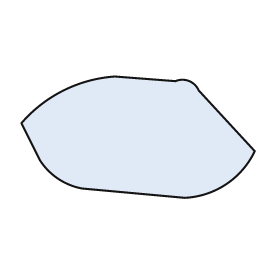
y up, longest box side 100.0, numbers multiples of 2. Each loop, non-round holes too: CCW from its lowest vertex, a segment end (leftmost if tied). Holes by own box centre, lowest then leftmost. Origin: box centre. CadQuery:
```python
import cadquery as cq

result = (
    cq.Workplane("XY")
    .moveTo(20.0, -26.0)
    .threePointArc((38.0, -20.0), (50.0, -6.0))
    .lineTo(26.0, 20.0)
    .threePointArc((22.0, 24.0), (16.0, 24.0))
    .lineTo(-10.0, 26.0)
    .threePointArc((-32.0, 20.0), (-50.0, 6.0))
    .lineTo(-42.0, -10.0)
    .threePointArc((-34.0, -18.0), (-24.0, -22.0))
    .close()
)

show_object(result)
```